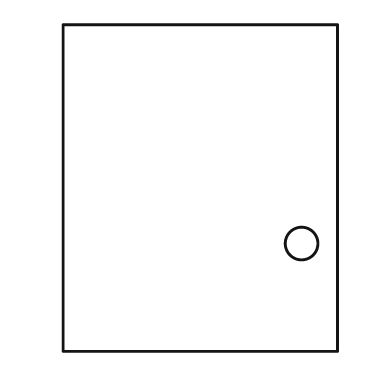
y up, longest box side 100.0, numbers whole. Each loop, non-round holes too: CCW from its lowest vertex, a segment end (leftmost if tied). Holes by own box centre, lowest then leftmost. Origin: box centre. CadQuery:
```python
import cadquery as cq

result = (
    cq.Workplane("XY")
    .moveTo(-42.0, -50.0)
    .lineTo(42.0, -50.0)
    .lineTo(42.0, 50.0)
    .lineTo(-42.0, 50.0)
    .close()
    .moveTo(31.0, -17.0)
    .circle(5.0)
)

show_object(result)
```